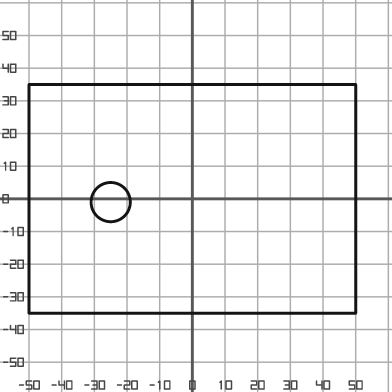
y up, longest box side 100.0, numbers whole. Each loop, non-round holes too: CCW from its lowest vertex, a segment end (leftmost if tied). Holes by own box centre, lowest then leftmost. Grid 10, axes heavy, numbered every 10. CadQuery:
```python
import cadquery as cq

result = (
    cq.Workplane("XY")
    .moveTo(-50.0, -35.0)
    .lineTo(50.0, -35.0)
    .lineTo(50.0, 35.0)
    .lineTo(-50.0, 35.0)
    .close()
    .moveTo(-25.0, -1.0)
    .circle(6.0)
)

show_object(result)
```